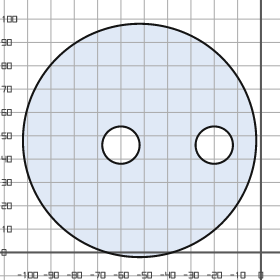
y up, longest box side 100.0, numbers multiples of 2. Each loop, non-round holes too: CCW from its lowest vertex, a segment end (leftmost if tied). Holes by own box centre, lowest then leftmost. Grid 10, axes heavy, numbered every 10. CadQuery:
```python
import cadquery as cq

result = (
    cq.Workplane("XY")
    .moveTo(-52.0, 48.0)
    .circle(50.0)
    .moveTo(-60.0, 46.0)
    .circle(8.0)
    .moveTo(-20.0, 46.0)
    .circle(8.0)
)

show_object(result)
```